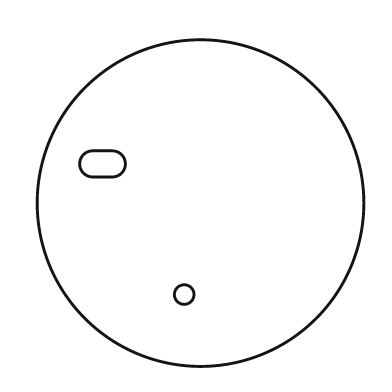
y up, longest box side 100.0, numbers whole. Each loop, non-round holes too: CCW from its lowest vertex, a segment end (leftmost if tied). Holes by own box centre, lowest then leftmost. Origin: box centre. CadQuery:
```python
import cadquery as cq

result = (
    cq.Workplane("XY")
    .moveTo(0.0, 0.0)
    .circle(50.0)
    .moveTo(-5.0, -28.0)
    .circle(3.0)
    .moveTo(-33.0, 8.0)
    .lineTo(-27.0, 8.0)
    .threePointArc((-23.0, 12.0), (-27.0, 16.0))
    .lineTo(-33.0, 16.0)
    .threePointArc((-37.0, 12.0), (-33.0, 8.0))
    .close()
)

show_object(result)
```